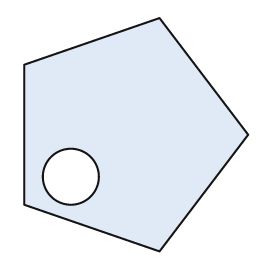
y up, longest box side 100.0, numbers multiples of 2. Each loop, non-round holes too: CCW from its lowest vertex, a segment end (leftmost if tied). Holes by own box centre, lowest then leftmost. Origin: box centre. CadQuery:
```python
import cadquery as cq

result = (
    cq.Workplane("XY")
    .moveTo(10.0, -50.0)
    .lineTo(48.0, 0.0)
    .lineTo(10.0, 50.0)
    .lineTo(-48.0, 30.0)
    .lineTo(-48.0, -30.0)
    .close()
    .moveTo(-28.0, -18.0)
    .circle(12.0)
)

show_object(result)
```